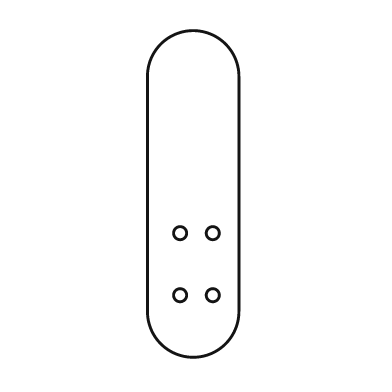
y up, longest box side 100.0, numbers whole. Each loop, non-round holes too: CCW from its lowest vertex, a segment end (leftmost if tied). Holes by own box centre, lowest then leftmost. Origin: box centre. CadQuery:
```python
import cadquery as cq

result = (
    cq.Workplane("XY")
    .moveTo(-14.0, -36.0)
    .threePointArc((0.0, -50.0), (14.0, -36.0))
    .lineTo(14.0, 36.0)
    .threePointArc((0.0, 50.0), (-14.0, 36.0))
    .close()
    .moveTo(-4.0, -31.0)
    .circle(2.0)
    .moveTo(6.0, -31.0)
    .circle(2.0)
    .moveTo(-4.0, -12.0)
    .circle(2.0)
    .moveTo(6.0, -12.0)
    .circle(2.0)
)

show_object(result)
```